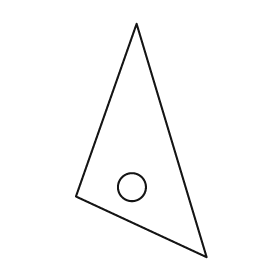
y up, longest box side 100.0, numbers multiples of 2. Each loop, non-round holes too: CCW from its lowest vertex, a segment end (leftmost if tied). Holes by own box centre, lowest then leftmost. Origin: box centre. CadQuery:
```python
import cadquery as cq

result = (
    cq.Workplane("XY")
    .moveTo(28.0, -50.0)
    .lineTo(-2.0, 50.0)
    .lineTo(-28.0, -24.0)
    .close()
    .moveTo(-4.0, -20.0)
    .circle(6.0)
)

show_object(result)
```